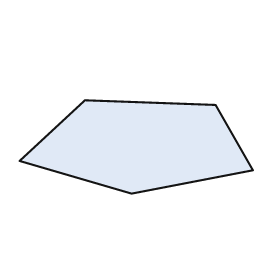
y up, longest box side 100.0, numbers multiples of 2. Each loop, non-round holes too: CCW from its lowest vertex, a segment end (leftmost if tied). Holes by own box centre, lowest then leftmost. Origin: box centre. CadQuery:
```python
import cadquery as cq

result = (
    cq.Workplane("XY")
    .moveTo(-2.0, -20.0)
    .lineTo(50.0, -10.0)
    .lineTo(34.0, 18.0)
    .lineTo(-22.0, 20.0)
    .lineTo(-50.0, -6.0)
    .close()
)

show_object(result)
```